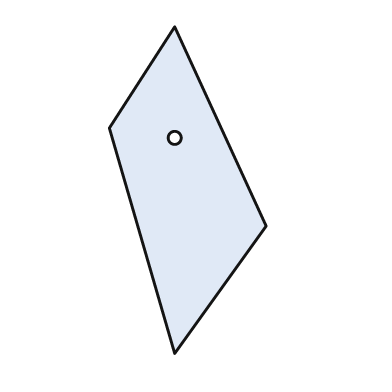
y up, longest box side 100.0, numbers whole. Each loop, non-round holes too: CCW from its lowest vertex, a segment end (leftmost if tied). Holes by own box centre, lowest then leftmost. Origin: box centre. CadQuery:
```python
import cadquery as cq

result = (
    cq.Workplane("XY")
    .moveTo(-4.0, -50.0)
    .lineTo(24.0, -11.0)
    .lineTo(-4.0, 50.0)
    .lineTo(-24.0, 19.0)
    .close()
    .moveTo(-4.0, 16.0)
    .circle(2.0)
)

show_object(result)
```